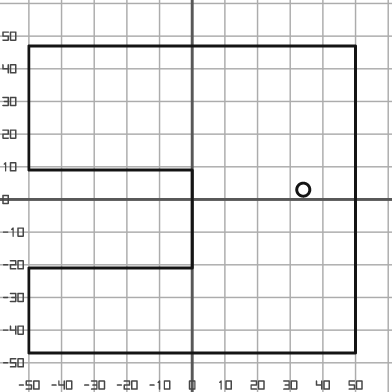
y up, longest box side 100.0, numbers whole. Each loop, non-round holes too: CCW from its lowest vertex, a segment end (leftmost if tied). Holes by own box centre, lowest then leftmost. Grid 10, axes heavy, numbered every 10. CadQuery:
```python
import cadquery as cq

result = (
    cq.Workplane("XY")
    .moveTo(-50.0, -47.0)
    .lineTo(50.0, -47.0)
    .lineTo(50.0, 47.0)
    .lineTo(-50.0, 47.0)
    .lineTo(-50.0, 9.0)
    .lineTo(0.0, 9.0)
    .lineTo(0.0, -21.0)
    .lineTo(-50.0, -21.0)
    .close()
    .moveTo(34.0, 3.0)
    .circle(2.0)
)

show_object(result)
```